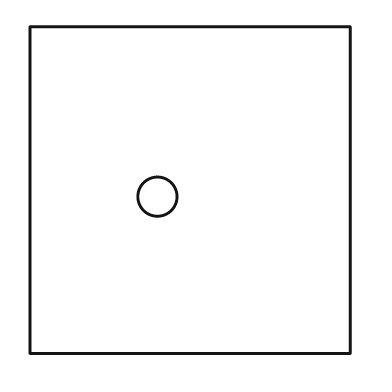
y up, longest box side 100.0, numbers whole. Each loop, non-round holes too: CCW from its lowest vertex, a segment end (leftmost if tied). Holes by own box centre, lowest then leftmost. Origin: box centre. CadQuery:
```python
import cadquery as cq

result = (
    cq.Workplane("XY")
    .moveTo(-49.0, -50.0)
    .lineTo(49.0, -50.0)
    .lineTo(49.0, 50.0)
    .lineTo(-49.0, 50.0)
    .close()
    .moveTo(-10.0, -2.0)
    .circle(6.0)
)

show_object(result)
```